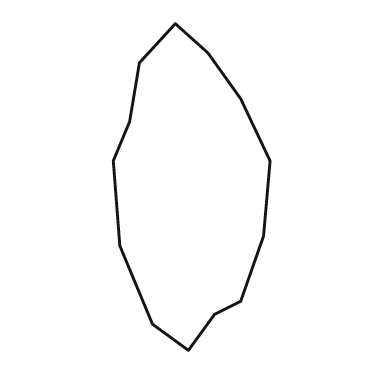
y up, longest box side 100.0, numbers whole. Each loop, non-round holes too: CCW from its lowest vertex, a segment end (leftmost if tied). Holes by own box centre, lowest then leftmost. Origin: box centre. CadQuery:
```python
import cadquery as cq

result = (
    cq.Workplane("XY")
    .moveTo(-1.0, -50.0)
    .lineTo(7.0, -39.0)
    .lineTo(15.0, -35.0)
    .lineTo(22.0, -15.0)
    .lineTo(24.0, 8.0)
    .lineTo(15.0, 27.0)
    .lineTo(5.0, 41.0)
    .lineTo(-5.0, 50.0)
    .lineTo(-16.0, 38.0)
    .lineTo(-19.0, 20.0)
    .lineTo(-24.0, 8.0)
    .lineTo(-22.0, -18.0)
    .lineTo(-12.0, -42.0)
    .close()
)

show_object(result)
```